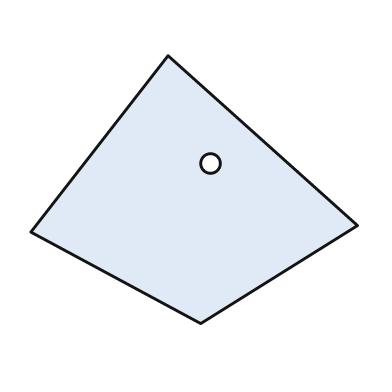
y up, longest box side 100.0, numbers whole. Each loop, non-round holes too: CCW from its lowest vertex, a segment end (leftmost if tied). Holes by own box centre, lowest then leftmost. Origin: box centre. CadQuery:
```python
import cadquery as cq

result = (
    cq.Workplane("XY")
    .moveTo(2.0, -41.0)
    .lineTo(50.0, -11.0)
    .lineTo(-8.0, 41.0)
    .lineTo(-50.0, -13.0)
    .close()
    .moveTo(5.0, 8.0)
    .circle(3.0)
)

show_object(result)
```